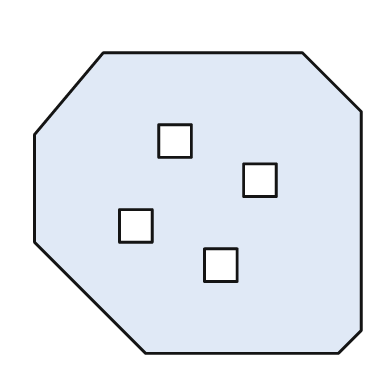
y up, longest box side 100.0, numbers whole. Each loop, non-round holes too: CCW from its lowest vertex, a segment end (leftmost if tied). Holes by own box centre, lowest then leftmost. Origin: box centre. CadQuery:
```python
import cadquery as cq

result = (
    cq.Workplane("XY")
    .moveTo(-16.0, -46.0)
    .lineTo(43.0, -46.0)
    .lineTo(50.0, -39.0)
    .lineTo(50.0, 28.0)
    .lineTo(32.0, 46.0)
    .lineTo(-29.0, 46.0)
    .lineTo(-50.0, 21.0)
    .lineTo(-50.0, -12.0)
    .close()
    .moveTo(2.0, -24.0)
    .lineTo(12.0, -24.0)
    .lineTo(12.0, -14.0)
    .lineTo(2.0, -14.0)
    .close()
    .moveTo(-24.0, -12.0)
    .lineTo(-14.0, -12.0)
    .lineTo(-14.0, -2.0)
    .lineTo(-24.0, -2.0)
    .close()
    .moveTo(14.0, 2.0)
    .lineTo(24.0, 2.0)
    .lineTo(24.0, 12.0)
    .lineTo(14.0, 12.0)
    .close()
    .moveTo(-12.0, 14.0)
    .lineTo(-2.0, 14.0)
    .lineTo(-2.0, 24.0)
    .lineTo(-12.0, 24.0)
    .close()
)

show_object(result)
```